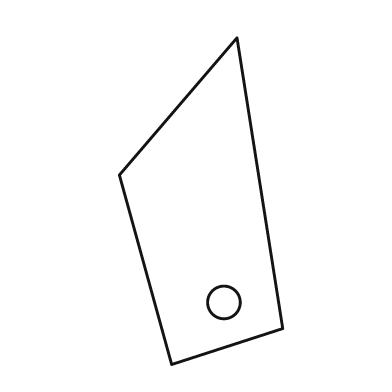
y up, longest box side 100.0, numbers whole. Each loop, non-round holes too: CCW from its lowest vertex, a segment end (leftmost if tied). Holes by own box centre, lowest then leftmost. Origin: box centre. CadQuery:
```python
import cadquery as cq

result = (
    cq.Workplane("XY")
    .moveTo(-9.0, -50.0)
    .lineTo(25.0, -39.0)
    .lineTo(11.0, 50.0)
    .lineTo(-25.0, 8.0)
    .close()
    .moveTo(7.0, -31.0)
    .circle(5.0)
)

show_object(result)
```